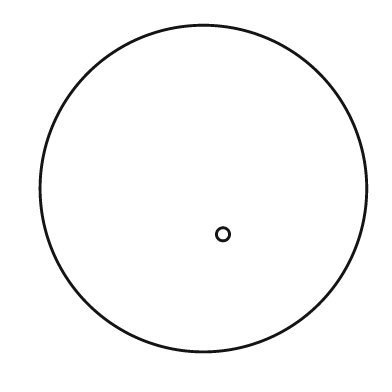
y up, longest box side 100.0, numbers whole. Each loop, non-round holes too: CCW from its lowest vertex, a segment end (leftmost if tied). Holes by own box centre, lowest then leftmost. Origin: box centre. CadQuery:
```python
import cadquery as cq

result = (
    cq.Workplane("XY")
    .moveTo(0.0, 0.0)
    .circle(50.0)
    .moveTo(6.0, -14.0)
    .circle(2.0)
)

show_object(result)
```